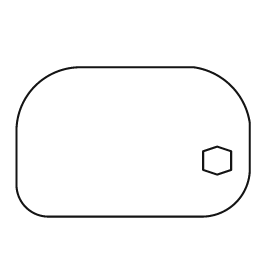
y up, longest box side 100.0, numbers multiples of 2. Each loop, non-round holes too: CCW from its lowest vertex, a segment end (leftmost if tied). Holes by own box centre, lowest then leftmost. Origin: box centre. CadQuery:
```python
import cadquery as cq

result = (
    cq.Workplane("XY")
    .moveTo(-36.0, -32.0)
    .lineTo(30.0, -32.0)
    .threePointArc((44.0, -26.0), (50.0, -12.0))
    .lineTo(50.0, 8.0)
    .threePointArc((42.0, 24.0), (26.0, 32.0))
    .lineTo(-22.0, 32.0)
    .threePointArc((-42.0, 24.0), (-50.0, 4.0))
    .lineTo(-50.0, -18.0)
    .threePointArc((-46.0, -28.0), (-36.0, -32.0))
    .close()
    .moveTo(36.0, -14.0)
    .lineTo(42.0, -12.0)
    .lineTo(42.0, -4.0)
    .lineTo(36.0, -2.0)
    .lineTo(30.0, -4.0)
    .lineTo(30.0, -12.0)
    .close()
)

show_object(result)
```